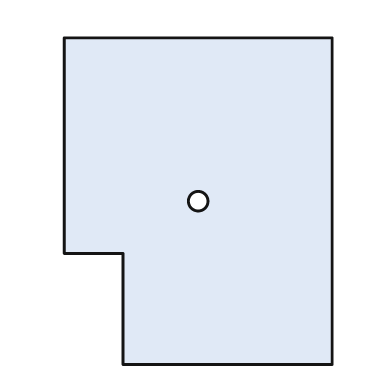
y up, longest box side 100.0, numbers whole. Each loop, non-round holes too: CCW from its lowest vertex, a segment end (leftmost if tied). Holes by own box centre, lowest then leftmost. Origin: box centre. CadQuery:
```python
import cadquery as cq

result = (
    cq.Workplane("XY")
    .moveTo(-23.0, -50.0)
    .lineTo(41.0, -50.0)
    .lineTo(41.0, 50.0)
    .lineTo(-41.0, 50.0)
    .lineTo(-41.0, -16.0)
    .lineTo(-23.0, -16.0)
    .close()
    .moveTo(0.0, 0.0)
    .circle(3.0)
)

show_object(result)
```